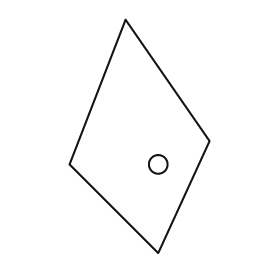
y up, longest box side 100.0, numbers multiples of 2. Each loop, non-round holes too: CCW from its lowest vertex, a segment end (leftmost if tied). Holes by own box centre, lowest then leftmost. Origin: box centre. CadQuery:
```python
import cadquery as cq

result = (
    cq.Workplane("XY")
    .moveTo(8.0, -50.0)
    .lineTo(30.0, -2.0)
    .lineTo(-6.0, 50.0)
    .lineTo(-30.0, -12.0)
    .close()
    .moveTo(8.0, -12.0)
    .circle(4.0)
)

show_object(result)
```